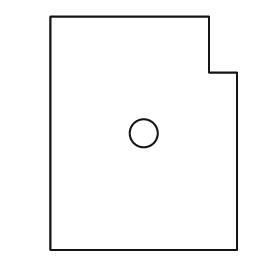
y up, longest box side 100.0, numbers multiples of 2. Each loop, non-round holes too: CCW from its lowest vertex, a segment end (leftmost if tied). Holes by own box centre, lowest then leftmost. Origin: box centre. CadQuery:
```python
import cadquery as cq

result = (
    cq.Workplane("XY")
    .moveTo(-40.0, -50.0)
    .lineTo(40.0, -50.0)
    .lineTo(40.0, 26.0)
    .lineTo(28.0, 26.0)
    .lineTo(28.0, 50.0)
    .lineTo(-40.0, 50.0)
    .close()
    .moveTo(0.0, 0.0)
    .circle(6.0)
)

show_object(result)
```